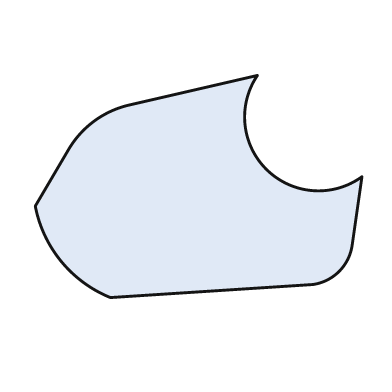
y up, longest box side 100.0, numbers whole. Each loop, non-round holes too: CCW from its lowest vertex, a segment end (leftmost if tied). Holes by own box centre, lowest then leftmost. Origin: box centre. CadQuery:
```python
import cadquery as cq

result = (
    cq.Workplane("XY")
    .moveTo(-27.0, -34.0)
    .lineTo(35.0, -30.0)
    .threePointArc((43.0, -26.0), (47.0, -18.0))
    .lineTo(50.0, 3.0)
    .threePointArc((21.0, 5.0), (18.0, 34.0))
    .lineTo(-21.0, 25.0)
    .threePointArc((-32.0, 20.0), (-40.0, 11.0))
    .lineTo(-50.0, -6.0)
    .threePointArc((-42.0, -23.0), (-27.0, -34.0))
    .close()
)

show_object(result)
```